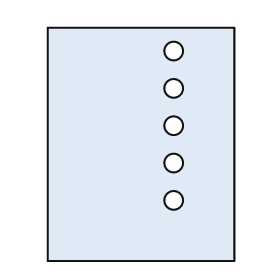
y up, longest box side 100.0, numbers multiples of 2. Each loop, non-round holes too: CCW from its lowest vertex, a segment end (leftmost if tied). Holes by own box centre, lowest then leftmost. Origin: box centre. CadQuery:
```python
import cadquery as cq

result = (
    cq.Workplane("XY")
    .moveTo(-40.0, -50.0)
    .lineTo(40.0, -50.0)
    .lineTo(40.0, 50.0)
    .lineTo(-40.0, 50.0)
    .close()
    .moveTo(14.0, -24.0)
    .circle(4.0)
    .moveTo(14.0, -8.0)
    .circle(4.0)
    .moveTo(14.0, 8.0)
    .circle(4.0)
    .moveTo(14.0, 24.0)
    .circle(4.0)
    .moveTo(14.0, 40.0)
    .circle(4.0)
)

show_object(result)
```